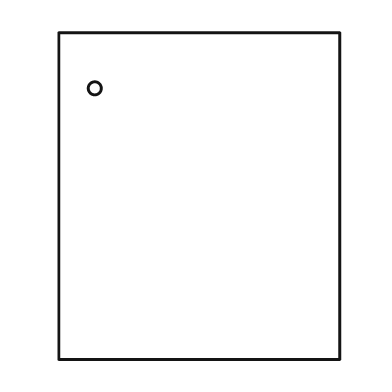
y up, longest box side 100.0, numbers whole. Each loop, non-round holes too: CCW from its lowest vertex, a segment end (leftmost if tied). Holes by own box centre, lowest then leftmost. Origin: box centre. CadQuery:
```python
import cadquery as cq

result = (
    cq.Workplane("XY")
    .moveTo(-43.0, -50.0)
    .lineTo(43.0, -50.0)
    .lineTo(43.0, 50.0)
    .lineTo(-43.0, 50.0)
    .close()
    .moveTo(-32.0, 33.0)
    .circle(2.0)
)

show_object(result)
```